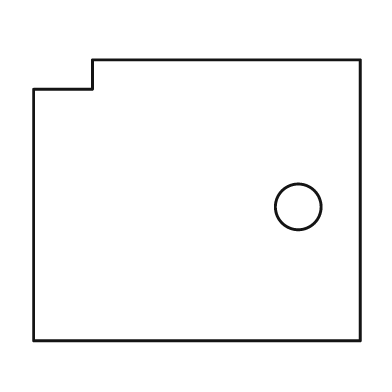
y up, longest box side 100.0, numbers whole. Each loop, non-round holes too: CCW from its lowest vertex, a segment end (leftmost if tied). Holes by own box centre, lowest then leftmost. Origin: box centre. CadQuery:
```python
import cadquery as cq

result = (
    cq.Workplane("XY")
    .moveTo(-50.0, -43.0)
    .lineTo(50.0, -43.0)
    .lineTo(50.0, 43.0)
    .lineTo(-32.0, 43.0)
    .lineTo(-32.0, 34.0)
    .lineTo(-50.0, 34.0)
    .close()
    .moveTo(31.0, -2.0)
    .circle(7.0)
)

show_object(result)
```